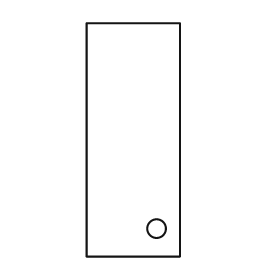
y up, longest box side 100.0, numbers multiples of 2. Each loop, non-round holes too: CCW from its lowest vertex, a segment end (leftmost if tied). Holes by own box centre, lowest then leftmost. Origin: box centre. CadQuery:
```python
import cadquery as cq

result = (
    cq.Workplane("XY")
    .moveTo(-20.0, -50.0)
    .lineTo(20.0, -50.0)
    .lineTo(20.0, 50.0)
    .lineTo(-20.0, 50.0)
    .close()
    .moveTo(10.0, -38.0)
    .circle(4.0)
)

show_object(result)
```